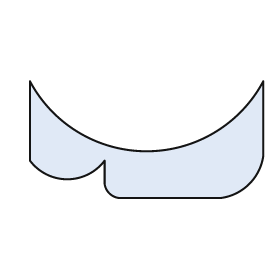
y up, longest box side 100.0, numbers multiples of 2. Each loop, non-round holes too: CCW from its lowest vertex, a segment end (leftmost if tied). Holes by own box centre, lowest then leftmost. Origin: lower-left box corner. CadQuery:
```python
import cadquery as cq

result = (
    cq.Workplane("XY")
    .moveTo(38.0, 0.0)
    .lineTo(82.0, 0.0)
    .threePointArc((94.0, 6.0), (100.0, 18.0))
    .lineTo(100.0, 50.0)
    .threePointArc((50.0, 20.0), (0.0, 50.0))
    .lineTo(0.0, 16.0)
    .threePointArc((16.0, 8.0), (32.0, 16.0))
    .lineTo(32.0, 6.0)
    .threePointArc((34.0, 2.0), (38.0, 0.0))
    .close()
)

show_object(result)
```